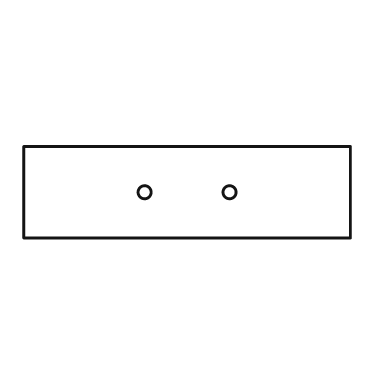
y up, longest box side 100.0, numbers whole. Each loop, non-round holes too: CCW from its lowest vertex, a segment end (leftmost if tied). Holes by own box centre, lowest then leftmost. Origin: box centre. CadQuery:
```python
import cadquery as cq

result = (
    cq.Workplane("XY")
    .moveTo(-50.0, -14.0)
    .lineTo(50.0, -14.0)
    .lineTo(50.0, 14.0)
    .lineTo(-50.0, 14.0)
    .close()
    .moveTo(-13.0, 0.0)
    .circle(2.0)
    .moveTo(13.0, 0.0)
    .circle(2.0)
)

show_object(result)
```